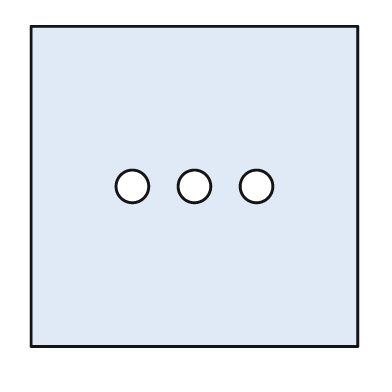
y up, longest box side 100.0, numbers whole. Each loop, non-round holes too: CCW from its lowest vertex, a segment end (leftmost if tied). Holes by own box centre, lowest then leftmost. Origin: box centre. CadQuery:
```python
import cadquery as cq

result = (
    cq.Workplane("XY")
    .moveTo(-50.0, -49.0)
    .lineTo(50.0, -49.0)
    .lineTo(50.0, 49.0)
    .lineTo(-50.0, 49.0)
    .close()
    .moveTo(-19.0, 0.0)
    .circle(5.0)
    .moveTo(0.0, 0.0)
    .circle(5.0)
    .moveTo(19.0, 0.0)
    .circle(5.0)
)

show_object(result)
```